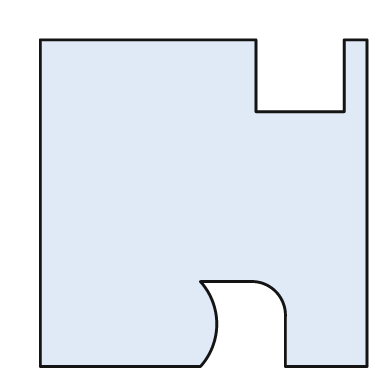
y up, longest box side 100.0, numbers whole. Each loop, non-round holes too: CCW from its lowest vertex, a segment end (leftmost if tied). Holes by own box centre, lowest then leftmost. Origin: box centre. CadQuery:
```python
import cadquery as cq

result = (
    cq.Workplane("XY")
    .moveTo(-50.0, -50.0)
    .lineTo(-1.0, -50.0)
    .threePointArc((4.0, -37.0), (-1.0, -24.0))
    .lineTo(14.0, -24.0)
    .threePointArc((22.0, -27.0), (25.0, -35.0))
    .lineTo(25.0, -50.0)
    .lineTo(50.0, -50.0)
    .lineTo(50.0, 50.0)
    .lineTo(43.0, 50.0)
    .lineTo(43.0, 28.0)
    .lineTo(16.0, 28.0)
    .lineTo(16.0, 50.0)
    .lineTo(-50.0, 50.0)
    .close()
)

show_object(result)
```